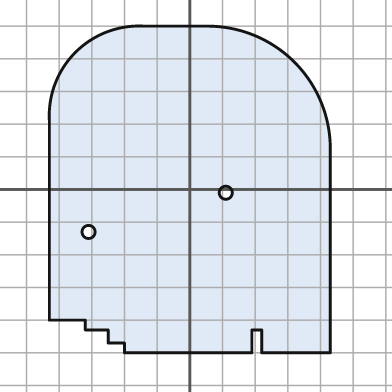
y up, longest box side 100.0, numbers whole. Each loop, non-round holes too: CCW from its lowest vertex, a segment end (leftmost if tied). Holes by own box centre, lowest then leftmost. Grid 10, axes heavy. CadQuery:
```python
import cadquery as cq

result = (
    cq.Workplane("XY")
    .moveTo(-20.0, -50.0)
    .lineTo(19.0, -50.0)
    .lineTo(19.0, -43.0)
    .lineTo(22.0, -43.0)
    .lineTo(22.0, -50.0)
    .lineTo(43.0, -50.0)
    .lineTo(43.0, 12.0)
    .threePointArc((32.0, 39.0), (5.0, 50.0))
    .lineTo(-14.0, 50.0)
    .threePointArc((-35.0, 42.0), (-43.0, 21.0))
    .lineTo(-43.0, -40.0)
    .lineTo(-32.0, -40.0)
    .lineTo(-32.0, -43.0)
    .lineTo(-25.0, -43.0)
    .lineTo(-25.0, -47.0)
    .lineTo(-20.0, -47.0)
    .close()
    .moveTo(-31.0, -13.0)
    .circle(2.0)
    .moveTo(11.0, -1.0)
    .circle(2.0)
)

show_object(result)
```